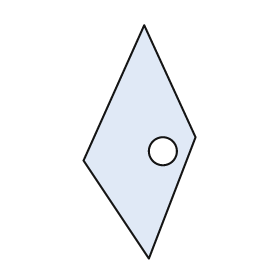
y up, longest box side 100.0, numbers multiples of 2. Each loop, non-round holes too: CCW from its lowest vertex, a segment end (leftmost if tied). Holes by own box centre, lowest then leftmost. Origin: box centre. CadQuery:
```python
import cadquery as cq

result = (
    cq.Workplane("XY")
    .moveTo(4.0, -50.0)
    .lineTo(24.0, 2.0)
    .lineTo(2.0, 50.0)
    .lineTo(-24.0, -8.0)
    .close()
    .moveTo(10.0, -4.0)
    .circle(6.0)
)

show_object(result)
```